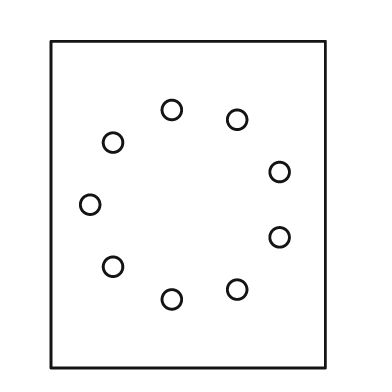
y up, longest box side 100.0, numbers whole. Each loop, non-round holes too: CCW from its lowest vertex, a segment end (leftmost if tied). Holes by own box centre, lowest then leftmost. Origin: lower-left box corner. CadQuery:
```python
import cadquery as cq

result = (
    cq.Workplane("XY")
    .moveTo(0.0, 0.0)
    .lineTo(84.0, 0.0)
    .lineTo(84.0, 100.0)
    .lineTo(0.0, 100.0)
    .close()
    .moveTo(37.0, 21.0)
    .circle(3.0)
    .moveTo(57.0, 24.0)
    .circle(3.0)
    .moveTo(19.0, 31.0)
    .circle(3.0)
    .moveTo(70.0, 40.0)
    .circle(3.0)
    .moveTo(12.0, 50.0)
    .circle(3.0)
    .moveTo(70.0, 60.0)
    .circle(3.0)
    .moveTo(19.0, 69.0)
    .circle(3.0)
    .moveTo(57.0, 76.0)
    .circle(3.0)
    .moveTo(37.0, 79.0)
    .circle(3.0)
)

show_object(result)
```